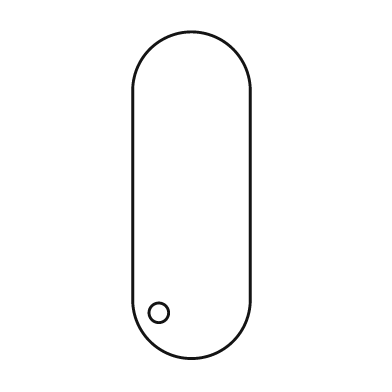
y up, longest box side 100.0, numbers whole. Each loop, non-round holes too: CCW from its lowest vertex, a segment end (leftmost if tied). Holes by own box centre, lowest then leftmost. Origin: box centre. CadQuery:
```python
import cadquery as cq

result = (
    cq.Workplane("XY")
    .moveTo(-18.0, -32.0)
    .threePointArc((0.0, -50.0), (18.0, -32.0))
    .lineTo(18.0, 32.0)
    .threePointArc((0.0, 50.0), (-18.0, 32.0))
    .close()
    .moveTo(-10.0, -36.0)
    .circle(3.0)
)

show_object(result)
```